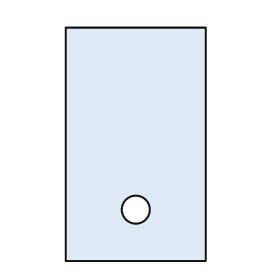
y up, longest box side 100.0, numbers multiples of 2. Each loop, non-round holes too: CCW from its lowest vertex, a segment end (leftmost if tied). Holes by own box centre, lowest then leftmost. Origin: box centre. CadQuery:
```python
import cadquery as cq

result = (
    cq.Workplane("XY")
    .moveTo(-30.0, -50.0)
    .lineTo(30.0, -50.0)
    .lineTo(30.0, 50.0)
    .lineTo(-30.0, 50.0)
    .close()
    .moveTo(0.0, -28.0)
    .circle(6.0)
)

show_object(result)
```